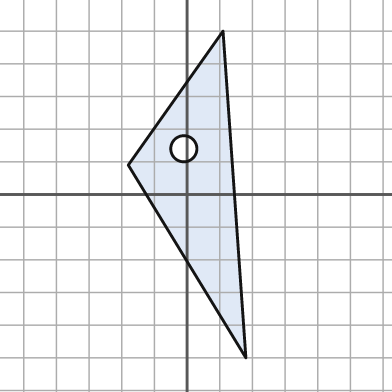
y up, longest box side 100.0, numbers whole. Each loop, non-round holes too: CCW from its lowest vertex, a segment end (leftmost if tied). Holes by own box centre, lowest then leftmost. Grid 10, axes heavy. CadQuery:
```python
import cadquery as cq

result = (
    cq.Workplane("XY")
    .moveTo(18.0, -50.0)
    .lineTo(11.0, 50.0)
    .lineTo(-18.0, 9.0)
    .close()
    .moveTo(-1.0, 14.0)
    .circle(4.0)
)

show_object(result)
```